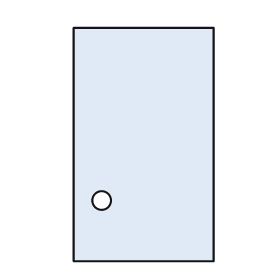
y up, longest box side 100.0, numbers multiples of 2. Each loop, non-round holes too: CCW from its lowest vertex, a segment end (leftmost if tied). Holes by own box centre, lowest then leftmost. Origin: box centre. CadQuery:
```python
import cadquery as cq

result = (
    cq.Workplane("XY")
    .moveTo(-30.0, -50.0)
    .lineTo(30.0, -50.0)
    .lineTo(30.0, 50.0)
    .lineTo(-30.0, 50.0)
    .close()
    .moveTo(-18.0, -24.0)
    .circle(4.0)
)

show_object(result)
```